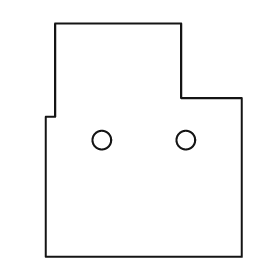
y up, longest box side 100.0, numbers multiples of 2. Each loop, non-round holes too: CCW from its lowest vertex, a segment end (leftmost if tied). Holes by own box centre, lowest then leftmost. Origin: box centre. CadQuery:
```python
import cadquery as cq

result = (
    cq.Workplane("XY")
    .moveTo(-42.0, -50.0)
    .lineTo(42.0, -50.0)
    .lineTo(42.0, 18.0)
    .lineTo(16.0, 18.0)
    .lineTo(16.0, 50.0)
    .lineTo(-38.0, 50.0)
    .lineTo(-38.0, 10.0)
    .lineTo(-42.0, 10.0)
    .close()
    .moveTo(-18.0, 0.0)
    .circle(4.0)
    .moveTo(18.0, 0.0)
    .circle(4.0)
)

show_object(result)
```